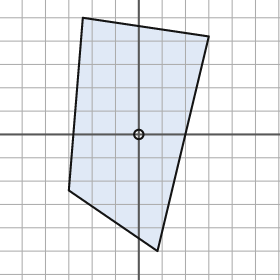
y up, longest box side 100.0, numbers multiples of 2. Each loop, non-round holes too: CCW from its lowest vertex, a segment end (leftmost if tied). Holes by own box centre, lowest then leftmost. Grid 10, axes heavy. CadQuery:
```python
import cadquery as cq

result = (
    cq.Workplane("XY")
    .moveTo(8.0, -50.0)
    .lineTo(30.0, 42.0)
    .lineTo(-24.0, 50.0)
    .lineTo(-30.0, -24.0)
    .close()
    .moveTo(0.0, 0.0)
    .circle(2.0)
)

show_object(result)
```